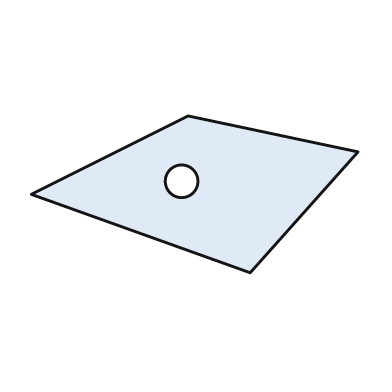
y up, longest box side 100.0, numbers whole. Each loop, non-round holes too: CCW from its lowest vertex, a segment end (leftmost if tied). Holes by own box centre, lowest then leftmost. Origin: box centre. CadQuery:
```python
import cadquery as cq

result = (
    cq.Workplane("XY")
    .moveTo(17.0, -24.0)
    .lineTo(50.0, 13.0)
    .lineTo(-2.0, 24.0)
    .lineTo(-50.0, 0.0)
    .close()
    .moveTo(-4.0, 4.0)
    .circle(5.0)
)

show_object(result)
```